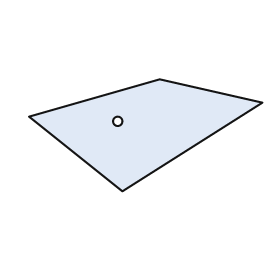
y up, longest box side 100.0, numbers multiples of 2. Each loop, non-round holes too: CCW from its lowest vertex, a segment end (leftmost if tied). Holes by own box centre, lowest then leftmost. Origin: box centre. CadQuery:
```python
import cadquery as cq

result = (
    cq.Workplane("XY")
    .moveTo(-10.0, -24.0)
    .lineTo(50.0, 14.0)
    .lineTo(6.0, 24.0)
    .lineTo(-50.0, 8.0)
    .close()
    .moveTo(-12.0, 6.0)
    .circle(2.0)
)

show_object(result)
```